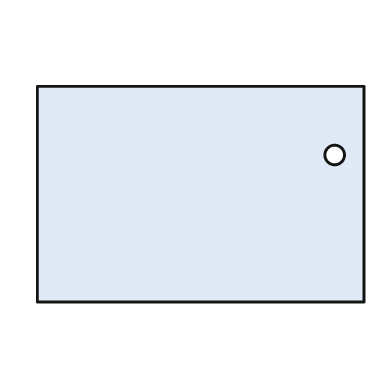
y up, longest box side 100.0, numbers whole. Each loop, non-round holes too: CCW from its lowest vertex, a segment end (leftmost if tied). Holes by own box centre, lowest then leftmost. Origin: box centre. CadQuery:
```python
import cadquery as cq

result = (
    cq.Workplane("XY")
    .moveTo(-50.0, -33.0)
    .lineTo(50.0, -33.0)
    .lineTo(50.0, 33.0)
    .lineTo(-50.0, 33.0)
    .close()
    .moveTo(41.0, 12.0)
    .circle(3.0)
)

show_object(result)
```